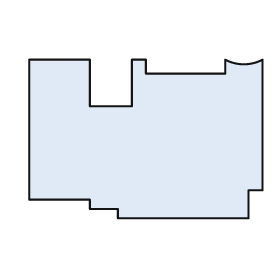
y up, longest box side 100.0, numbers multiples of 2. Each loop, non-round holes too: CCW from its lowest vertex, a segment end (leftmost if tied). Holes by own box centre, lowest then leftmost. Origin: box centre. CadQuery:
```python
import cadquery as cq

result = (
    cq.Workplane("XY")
    .moveTo(-12.0, -34.0)
    .lineTo(44.0, -34.0)
    .lineTo(44.0, -22.0)
    .lineTo(50.0, -22.0)
    .lineTo(50.0, 34.0)
    .threePointArc((42.0, 32.0), (34.0, 34.0))
    .lineTo(34.0, 28.0)
    .lineTo(0.0, 28.0)
    .lineTo(0.0, 34.0)
    .lineTo(-6.0, 34.0)
    .lineTo(-6.0, 14.0)
    .lineTo(-24.0, 14.0)
    .lineTo(-24.0, 34.0)
    .lineTo(-50.0, 34.0)
    .lineTo(-50.0, -26.0)
    .lineTo(-24.0, -26.0)
    .lineTo(-24.0, -30.0)
    .lineTo(-12.0, -30.0)
    .close()
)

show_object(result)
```